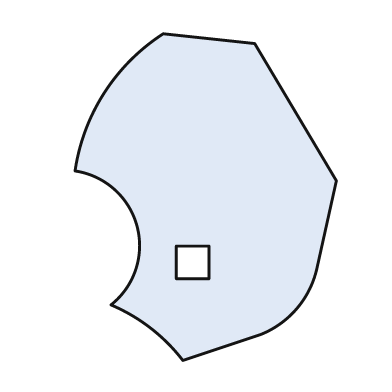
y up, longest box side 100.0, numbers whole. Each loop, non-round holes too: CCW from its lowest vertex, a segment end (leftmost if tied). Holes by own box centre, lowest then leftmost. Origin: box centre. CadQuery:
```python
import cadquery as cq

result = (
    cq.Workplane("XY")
    .moveTo(-7.0, -50.0)
    .lineTo(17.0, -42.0)
    .threePointArc((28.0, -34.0), (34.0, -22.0))
    .lineTo(40.0, 5.0)
    .lineTo(15.0, 47.0)
    .lineTo(-13.0, 50.0)
    .threePointArc((-31.0, 32.0), (-40.0, 8.0))
    .threePointArc((-21.0, -9.0), (-29.0, -33.0))
    .threePointArc((-17.0, -40.0), (-7.0, -50.0))
    .close()
    .moveTo(-9.0, -25.0)
    .lineTo(1.0, -25.0)
    .lineTo(1.0, -15.0)
    .lineTo(-9.0, -15.0)
    .close()
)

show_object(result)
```